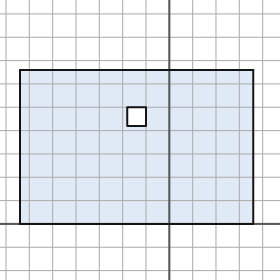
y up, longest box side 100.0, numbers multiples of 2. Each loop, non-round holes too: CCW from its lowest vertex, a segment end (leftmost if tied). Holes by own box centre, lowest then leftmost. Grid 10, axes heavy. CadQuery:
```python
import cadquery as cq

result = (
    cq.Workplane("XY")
    .moveTo(-64.0, 0.0)
    .lineTo(36.0, 0.0)
    .lineTo(36.0, 66.0)
    .lineTo(-64.0, 66.0)
    .close()
    .moveTo(-18.0, 42.0)
    .lineTo(-10.0, 42.0)
    .lineTo(-10.0, 50.0)
    .lineTo(-18.0, 50.0)
    .close()
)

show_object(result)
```